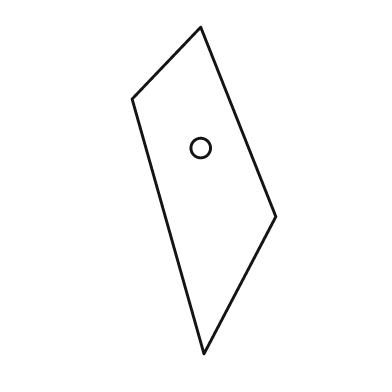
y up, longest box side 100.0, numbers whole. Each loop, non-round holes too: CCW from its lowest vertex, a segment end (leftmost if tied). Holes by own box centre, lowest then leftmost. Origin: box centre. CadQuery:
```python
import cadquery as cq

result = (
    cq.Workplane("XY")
    .moveTo(0.0, -50.0)
    .lineTo(22.0, -8.0)
    .lineTo(-1.0, 50.0)
    .lineTo(-22.0, 28.0)
    .close()
    .moveTo(-1.0, 13.0)
    .circle(3.0)
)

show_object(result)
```